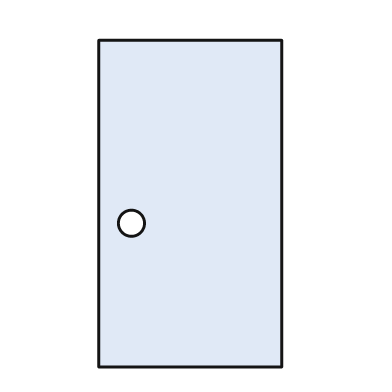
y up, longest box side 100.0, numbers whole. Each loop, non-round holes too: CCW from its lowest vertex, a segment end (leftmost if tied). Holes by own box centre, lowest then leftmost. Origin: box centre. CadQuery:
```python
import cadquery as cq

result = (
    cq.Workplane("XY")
    .moveTo(-28.0, -50.0)
    .lineTo(28.0, -50.0)
    .lineTo(28.0, 50.0)
    .lineTo(-28.0, 50.0)
    .close()
    .moveTo(-18.0, -6.0)
    .circle(4.0)
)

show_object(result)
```